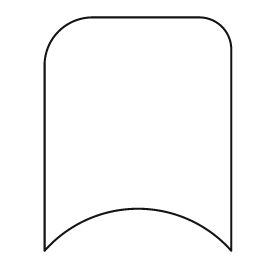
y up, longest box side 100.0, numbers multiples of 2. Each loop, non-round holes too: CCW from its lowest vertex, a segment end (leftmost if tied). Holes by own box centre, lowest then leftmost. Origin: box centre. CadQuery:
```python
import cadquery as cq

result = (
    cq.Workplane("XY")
    .moveTo(-40.0, -50.0)
    .threePointArc((0.0, -32.0), (40.0, -50.0))
    .lineTo(40.0, 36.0)
    .threePointArc((36.0, 46.0), (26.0, 50.0))
    .lineTo(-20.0, 50.0)
    .threePointArc((-34.0, 44.0), (-40.0, 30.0))
    .close()
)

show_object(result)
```